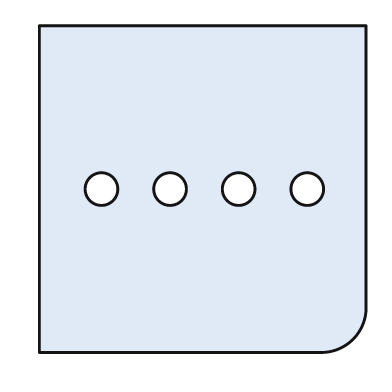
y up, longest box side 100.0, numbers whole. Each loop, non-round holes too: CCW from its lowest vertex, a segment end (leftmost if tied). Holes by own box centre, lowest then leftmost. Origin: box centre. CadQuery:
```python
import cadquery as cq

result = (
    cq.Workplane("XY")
    .moveTo(-50.0, -50.0)
    .lineTo(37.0, -50.0)
    .threePointArc((46.0, -46.0), (50.0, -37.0))
    .lineTo(50.0, 50.0)
    .lineTo(-50.0, 50.0)
    .close()
    .moveTo(-31.0, 0.0)
    .circle(5.0)
    .moveTo(-10.0, 0.0)
    .circle(5.0)
    .moveTo(11.0, 0.0)
    .circle(5.0)
    .moveTo(32.0, 0.0)
    .circle(5.0)
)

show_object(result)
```